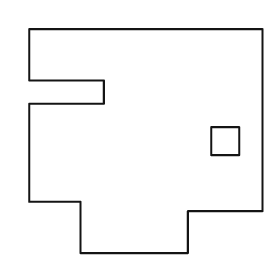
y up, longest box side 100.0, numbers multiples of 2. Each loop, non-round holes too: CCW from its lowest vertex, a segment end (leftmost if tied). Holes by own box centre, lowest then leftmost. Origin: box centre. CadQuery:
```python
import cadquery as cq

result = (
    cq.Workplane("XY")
    .moveTo(-28.0, -48.0)
    .lineTo(18.0, -48.0)
    .lineTo(18.0, -30.0)
    .lineTo(50.0, -30.0)
    .lineTo(50.0, 48.0)
    .lineTo(-50.0, 48.0)
    .lineTo(-50.0, 26.0)
    .lineTo(-18.0, 26.0)
    .lineTo(-18.0, 16.0)
    .lineTo(-50.0, 16.0)
    .lineTo(-50.0, -26.0)
    .lineTo(-28.0, -26.0)
    .close()
    .moveTo(28.0, -6.0)
    .lineTo(40.0, -6.0)
    .lineTo(40.0, 6.0)
    .lineTo(28.0, 6.0)
    .close()
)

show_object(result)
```